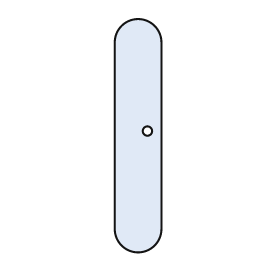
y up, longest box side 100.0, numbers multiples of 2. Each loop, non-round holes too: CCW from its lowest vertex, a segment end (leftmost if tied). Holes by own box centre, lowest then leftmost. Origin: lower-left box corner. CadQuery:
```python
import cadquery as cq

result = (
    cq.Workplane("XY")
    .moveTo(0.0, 10.0)
    .threePointArc((10.0, 0.0), (20.0, 10.0))
    .lineTo(20.0, 90.0)
    .threePointArc((10.0, 100.0), (0.0, 90.0))
    .close()
    .moveTo(14.0, 52.0)
    .circle(2.0)
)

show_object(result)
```